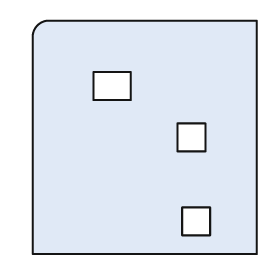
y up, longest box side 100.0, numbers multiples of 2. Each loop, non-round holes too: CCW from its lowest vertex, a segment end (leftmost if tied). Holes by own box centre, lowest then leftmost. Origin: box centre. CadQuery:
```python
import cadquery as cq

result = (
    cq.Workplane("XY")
    .moveTo(-48.0, -50.0)
    .lineTo(48.0, -50.0)
    .lineTo(48.0, 50.0)
    .lineTo(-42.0, 50.0)
    .threePointArc((-46.0, 48.0), (-48.0, 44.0))
    .close()
    .moveTo(16.0, -42.0)
    .lineTo(28.0, -42.0)
    .lineTo(28.0, -30.0)
    .lineTo(16.0, -30.0)
    .close()
    .moveTo(14.0, -6.0)
    .lineTo(26.0, -6.0)
    .lineTo(26.0, 6.0)
    .lineTo(14.0, 6.0)
    .close()
    .moveTo(-22.0, 16.0)
    .lineTo(-6.0, 16.0)
    .lineTo(-6.0, 28.0)
    .lineTo(-22.0, 28.0)
    .close()
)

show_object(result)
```